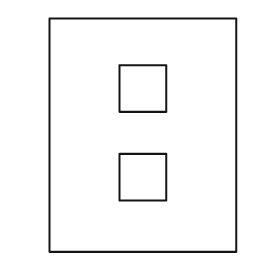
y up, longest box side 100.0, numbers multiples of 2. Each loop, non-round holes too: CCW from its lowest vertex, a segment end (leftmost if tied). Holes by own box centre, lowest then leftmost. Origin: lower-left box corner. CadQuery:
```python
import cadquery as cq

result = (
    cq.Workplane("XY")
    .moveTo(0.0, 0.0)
    .lineTo(80.0, 0.0)
    .lineTo(80.0, 100.0)
    .lineTo(0.0, 100.0)
    .close()
    .moveTo(30.0, 22.0)
    .lineTo(50.0, 22.0)
    .lineTo(50.0, 42.0)
    .lineTo(30.0, 42.0)
    .close()
    .moveTo(30.0, 60.0)
    .lineTo(50.0, 60.0)
    .lineTo(50.0, 80.0)
    .lineTo(30.0, 80.0)
    .close()
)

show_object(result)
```